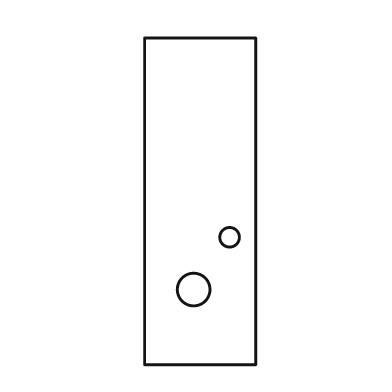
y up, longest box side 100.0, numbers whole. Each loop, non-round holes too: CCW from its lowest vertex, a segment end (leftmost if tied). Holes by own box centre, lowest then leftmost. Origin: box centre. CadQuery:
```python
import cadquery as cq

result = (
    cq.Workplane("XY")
    .moveTo(-17.0, -50.0)
    .lineTo(17.0, -50.0)
    .lineTo(17.0, 50.0)
    .lineTo(-17.0, 50.0)
    .close()
    .moveTo(-2.0, -27.0)
    .circle(5.0)
    .moveTo(9.0, -11.0)
    .circle(3.0)
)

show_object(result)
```